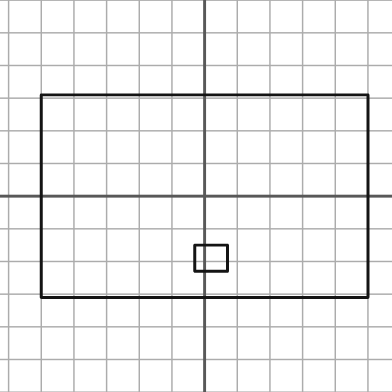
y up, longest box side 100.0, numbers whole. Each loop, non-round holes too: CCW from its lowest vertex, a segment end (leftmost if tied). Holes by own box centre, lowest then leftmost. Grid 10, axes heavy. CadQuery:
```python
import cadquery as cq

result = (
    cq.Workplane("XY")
    .moveTo(-50.0, -31.0)
    .lineTo(50.0, -31.0)
    .lineTo(50.0, 31.0)
    .lineTo(-50.0, 31.0)
    .close()
    .moveTo(-3.0, -23.0)
    .lineTo(7.0, -23.0)
    .lineTo(7.0, -15.0)
    .lineTo(-3.0, -15.0)
    .close()
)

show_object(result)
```